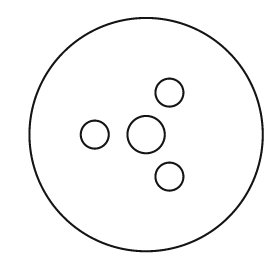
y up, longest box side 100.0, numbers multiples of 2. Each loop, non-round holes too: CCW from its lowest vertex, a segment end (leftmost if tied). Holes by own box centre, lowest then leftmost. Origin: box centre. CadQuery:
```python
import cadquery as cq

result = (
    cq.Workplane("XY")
    .moveTo(0.0, 0.0)
    .circle(50.0)
    .moveTo(10.0, -18.0)
    .circle(6.0)
    .moveTo(-22.0, 0.0)
    .circle(6.0)
    .moveTo(0.0, 0.0)
    .circle(8.0)
    .moveTo(10.0, 18.0)
    .circle(6.0)
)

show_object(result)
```